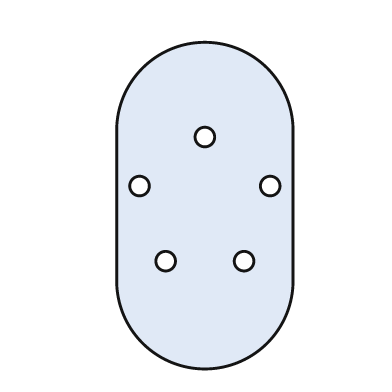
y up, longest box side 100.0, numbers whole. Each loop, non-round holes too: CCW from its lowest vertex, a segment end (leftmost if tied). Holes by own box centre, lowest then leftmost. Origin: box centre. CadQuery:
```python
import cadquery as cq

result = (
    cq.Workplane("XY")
    .moveTo(-27.0, -23.0)
    .threePointArc((0.0, -50.0), (27.0, -23.0))
    .lineTo(27.0, 23.0)
    .threePointArc((0.0, 50.0), (-27.0, 23.0))
    .close()
    .moveTo(-12.0, -17.0)
    .circle(3.0)
    .moveTo(12.0, -17.0)
    .circle(3.0)
    .moveTo(-20.0, 6.0)
    .circle(3.0)
    .moveTo(20.0, 6.0)
    .circle(3.0)
    .moveTo(0.0, 21.0)
    .circle(3.0)
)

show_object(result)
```